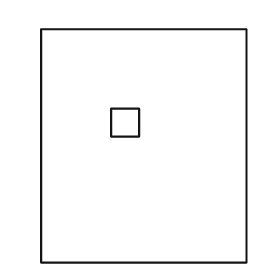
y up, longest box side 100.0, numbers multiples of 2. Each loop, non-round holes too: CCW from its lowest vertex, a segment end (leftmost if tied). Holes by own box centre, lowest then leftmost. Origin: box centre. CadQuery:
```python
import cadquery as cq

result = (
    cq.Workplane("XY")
    .moveTo(-44.0, -50.0)
    .lineTo(44.0, -50.0)
    .lineTo(44.0, 50.0)
    .lineTo(-44.0, 50.0)
    .close()
    .moveTo(-14.0, 4.0)
    .lineTo(-2.0, 4.0)
    .lineTo(-2.0, 16.0)
    .lineTo(-14.0, 16.0)
    .close()
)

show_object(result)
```